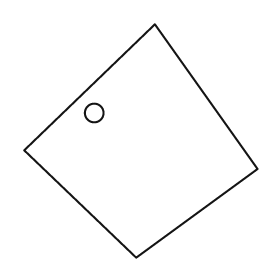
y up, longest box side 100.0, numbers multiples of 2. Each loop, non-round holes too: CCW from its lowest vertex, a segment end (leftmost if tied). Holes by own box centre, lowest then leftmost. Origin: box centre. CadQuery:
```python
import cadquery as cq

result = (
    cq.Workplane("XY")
    .moveTo(-2.0, -50.0)
    .lineTo(50.0, -12.0)
    .lineTo(6.0, 50.0)
    .lineTo(-50.0, -4.0)
    .close()
    .moveTo(-20.0, 12.0)
    .circle(4.0)
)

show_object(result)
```